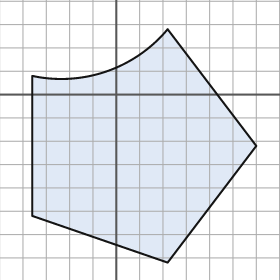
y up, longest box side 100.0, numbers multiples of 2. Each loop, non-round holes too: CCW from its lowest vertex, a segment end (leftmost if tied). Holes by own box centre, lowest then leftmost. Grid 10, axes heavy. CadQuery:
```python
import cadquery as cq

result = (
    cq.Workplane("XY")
    .moveTo(22.0, -72.0)
    .lineTo(60.0, -22.0)
    .lineTo(22.0, 28.0)
    .threePointArc((-4.0, 10.0), (-36.0, 8.0))
    .lineTo(-36.0, -52.0)
    .close()
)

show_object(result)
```